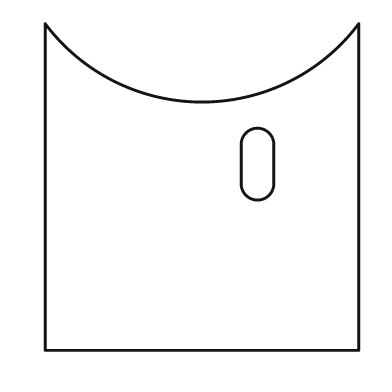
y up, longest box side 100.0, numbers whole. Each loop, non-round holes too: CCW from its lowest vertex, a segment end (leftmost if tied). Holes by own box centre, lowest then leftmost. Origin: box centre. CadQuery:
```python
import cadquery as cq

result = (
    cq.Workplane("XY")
    .moveTo(-48.0, -50.0)
    .lineTo(48.0, -50.0)
    .lineTo(48.0, 50.0)
    .threePointArc((0.0, 26.0), (-48.0, 50.0))
    .close()
    .moveTo(12.0, 1.0)
    .threePointArc((17.0, -4.0), (22.0, 1.0))
    .lineTo(22.0, 13.0)
    .threePointArc((17.0, 18.0), (12.0, 13.0))
    .close()
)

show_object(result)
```